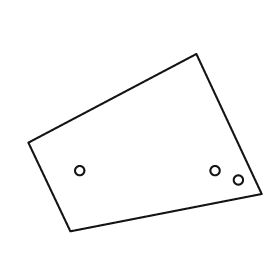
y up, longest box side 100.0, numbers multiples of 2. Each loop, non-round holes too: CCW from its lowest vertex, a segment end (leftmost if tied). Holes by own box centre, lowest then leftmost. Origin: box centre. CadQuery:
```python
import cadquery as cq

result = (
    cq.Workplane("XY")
    .moveTo(-32.0, -38.0)
    .lineTo(50.0, -22.0)
    .lineTo(22.0, 38.0)
    .lineTo(-50.0, 0.0)
    .close()
    .moveTo(40.0, -16.0)
    .circle(2.0)
    .moveTo(-28.0, -12.0)
    .circle(2.0)
    .moveTo(30.0, -12.0)
    .circle(2.0)
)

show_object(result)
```